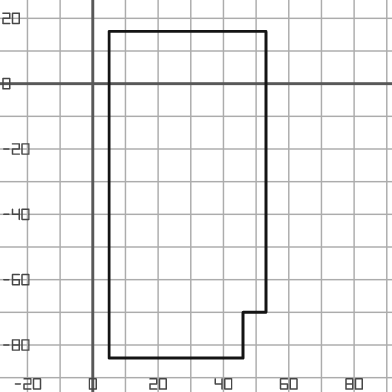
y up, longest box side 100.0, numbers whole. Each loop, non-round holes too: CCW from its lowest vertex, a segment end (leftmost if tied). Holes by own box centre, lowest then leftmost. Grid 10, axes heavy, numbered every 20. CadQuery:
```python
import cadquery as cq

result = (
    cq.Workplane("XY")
    .moveTo(5.0, -84.0)
    .lineTo(46.0, -84.0)
    .lineTo(46.0, -70.0)
    .lineTo(53.0, -70.0)
    .lineTo(53.0, 16.0)
    .lineTo(5.0, 16.0)
    .close()
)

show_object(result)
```